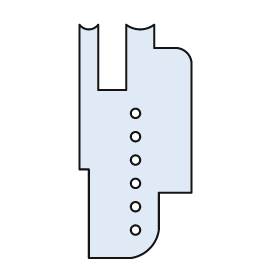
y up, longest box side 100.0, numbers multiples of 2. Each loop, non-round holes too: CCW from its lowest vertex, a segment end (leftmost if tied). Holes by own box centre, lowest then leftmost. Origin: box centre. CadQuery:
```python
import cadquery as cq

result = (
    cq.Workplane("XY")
    .moveTo(-20.0, -50.0)
    .lineTo(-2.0, -50.0)
    .threePointArc((6.0, -46.0), (10.0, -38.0))
    .lineTo(10.0, -22.0)
    .lineTo(24.0, -22.0)
    .lineTo(24.0, 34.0)
    .threePointArc((22.0, 38.0), (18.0, 40.0))
    .lineTo(8.0, 40.0)
    .lineTo(8.0, 50.0)
    .threePointArc((2.0, 48.0), (-4.0, 50.0))
    .lineTo(-4.0, 22.0)
    .lineTo(-16.0, 22.0)
    .lineTo(-16.0, 50.0)
    .threePointArc((-20.0, 48.0), (-24.0, 50.0))
    .lineTo(-24.0, -12.0)
    .lineTo(-20.0, -12.0)
    .close()
    .moveTo(0.0, -38.0)
    .circle(2.0)
    .moveTo(0.0, -28.0)
    .circle(2.0)
    .moveTo(0.0, -18.0)
    .circle(2.0)
    .moveTo(0.0, -8.0)
    .circle(2.0)
    .moveTo(0.0, 2.0)
    .circle(2.0)
    .moveTo(0.0, 12.0)
    .circle(2.0)
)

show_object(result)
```